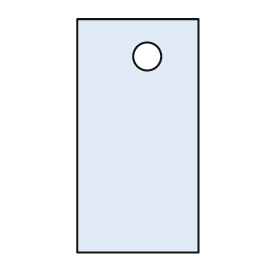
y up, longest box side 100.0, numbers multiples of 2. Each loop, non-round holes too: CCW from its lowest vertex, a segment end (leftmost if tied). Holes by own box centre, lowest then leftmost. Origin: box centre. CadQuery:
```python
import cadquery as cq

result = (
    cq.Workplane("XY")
    .moveTo(-26.0, -50.0)
    .lineTo(26.0, -50.0)
    .lineTo(26.0, 50.0)
    .lineTo(-26.0, 50.0)
    .close()
    .moveTo(4.0, 34.0)
    .circle(6.0)
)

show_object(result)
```